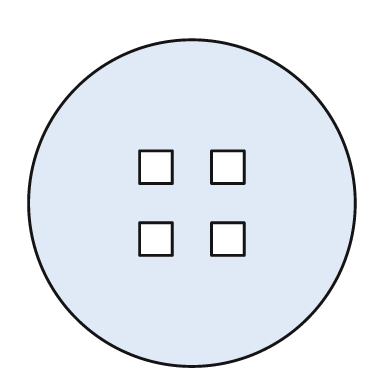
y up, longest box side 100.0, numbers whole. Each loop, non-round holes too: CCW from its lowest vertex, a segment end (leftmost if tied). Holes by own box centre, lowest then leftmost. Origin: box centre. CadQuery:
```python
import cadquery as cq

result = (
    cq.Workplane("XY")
    .moveTo(0.0, 0.0)
    .circle(50.0)
    .moveTo(-16.0, -16.0)
    .lineTo(-6.0, -16.0)
    .lineTo(-6.0, -6.0)
    .lineTo(-16.0, -6.0)
    .close()
    .moveTo(6.0, -16.0)
    .lineTo(16.0, -16.0)
    .lineTo(16.0, -6.0)
    .lineTo(6.0, -6.0)
    .close()
    .moveTo(-16.0, 6.0)
    .lineTo(-6.0, 6.0)
    .lineTo(-6.0, 16.0)
    .lineTo(-16.0, 16.0)
    .close()
    .moveTo(6.0, 6.0)
    .lineTo(16.0, 6.0)
    .lineTo(16.0, 16.0)
    .lineTo(6.0, 16.0)
    .close()
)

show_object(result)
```